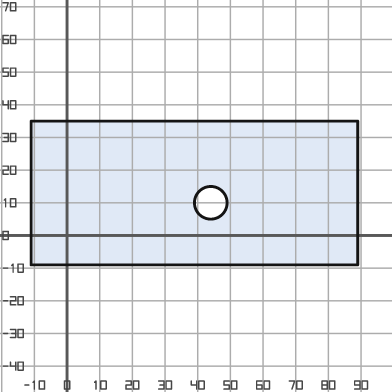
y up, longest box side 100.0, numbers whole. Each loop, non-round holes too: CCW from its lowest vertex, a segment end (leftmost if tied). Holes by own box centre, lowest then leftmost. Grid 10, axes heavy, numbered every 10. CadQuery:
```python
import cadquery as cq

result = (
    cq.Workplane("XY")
    .moveTo(-11.0, -9.0)
    .lineTo(89.0, -9.0)
    .lineTo(89.0, 35.0)
    .lineTo(-11.0, 35.0)
    .close()
    .moveTo(44.0, 10.0)
    .circle(5.0)
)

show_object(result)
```